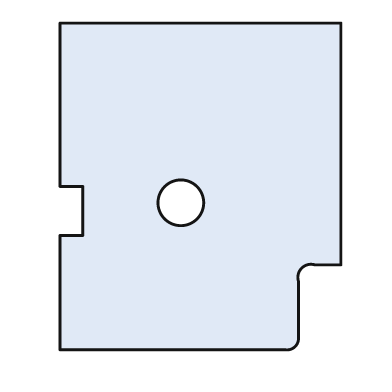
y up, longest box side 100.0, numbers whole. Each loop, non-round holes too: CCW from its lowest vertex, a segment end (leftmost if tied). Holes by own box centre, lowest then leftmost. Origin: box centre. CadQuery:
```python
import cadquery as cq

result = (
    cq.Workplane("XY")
    .moveTo(-43.0, -50.0)
    .lineTo(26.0, -50.0)
    .threePointArc((29.0, -49.0), (30.0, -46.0))
    .lineTo(30.0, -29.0)
    .threePointArc((31.0, -25.0), (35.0, -24.0))
    .lineTo(43.0, -24.0)
    .lineTo(43.0, 50.0)
    .lineTo(-43.0, 50.0)
    .lineTo(-43.0, 0.0)
    .lineTo(-36.0, 0.0)
    .lineTo(-36.0, -15.0)
    .lineTo(-43.0, -15.0)
    .close()
    .moveTo(-6.0, -5.0)
    .circle(7.0)
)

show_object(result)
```